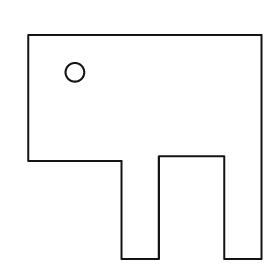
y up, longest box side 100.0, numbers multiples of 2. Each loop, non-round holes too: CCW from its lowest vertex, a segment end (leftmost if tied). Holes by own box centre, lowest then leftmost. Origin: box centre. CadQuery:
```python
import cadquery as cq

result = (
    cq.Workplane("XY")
    .moveTo(-10.0, -48.0)
    .lineTo(6.0, -48.0)
    .lineTo(6.0, -4.0)
    .lineTo(34.0, -4.0)
    .lineTo(34.0, -48.0)
    .lineTo(50.0, -48.0)
    .lineTo(50.0, 48.0)
    .lineTo(-50.0, 48.0)
    .lineTo(-50.0, -6.0)
    .lineTo(-10.0, -6.0)
    .close()
    .moveTo(-30.0, 32.0)
    .circle(4.0)
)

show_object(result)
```